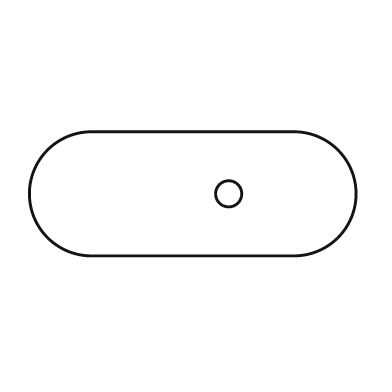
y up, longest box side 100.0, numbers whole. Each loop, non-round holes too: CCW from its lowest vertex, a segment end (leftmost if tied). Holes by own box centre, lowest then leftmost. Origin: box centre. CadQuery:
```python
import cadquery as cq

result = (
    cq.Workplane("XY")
    .moveTo(-31.0, -19.0)
    .lineTo(31.0, -19.0)
    .threePointArc((50.0, 0.0), (31.0, 19.0))
    .lineTo(-31.0, 19.0)
    .threePointArc((-50.0, 0.0), (-31.0, -19.0))
    .close()
    .moveTo(11.0, 0.0)
    .circle(4.0)
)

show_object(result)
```